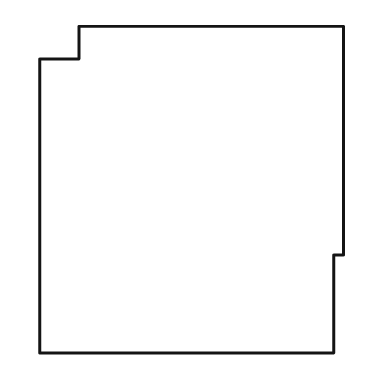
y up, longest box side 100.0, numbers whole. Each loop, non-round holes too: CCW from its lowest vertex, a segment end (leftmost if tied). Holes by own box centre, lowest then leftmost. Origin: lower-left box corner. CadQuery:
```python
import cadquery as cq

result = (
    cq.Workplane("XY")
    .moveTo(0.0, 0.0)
    .lineTo(90.0, 0.0)
    .lineTo(90.0, 30.0)
    .lineTo(93.0, 30.0)
    .lineTo(93.0, 100.0)
    .lineTo(12.0, 100.0)
    .lineTo(12.0, 90.0)
    .lineTo(0.0, 90.0)
    .close()
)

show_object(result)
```